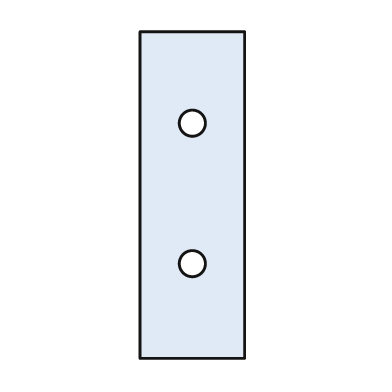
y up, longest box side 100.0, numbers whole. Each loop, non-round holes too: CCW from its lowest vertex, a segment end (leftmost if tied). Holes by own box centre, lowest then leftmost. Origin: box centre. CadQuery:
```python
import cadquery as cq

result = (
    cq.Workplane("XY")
    .moveTo(-16.0, -50.0)
    .lineTo(16.0, -50.0)
    .lineTo(16.0, 50.0)
    .lineTo(-16.0, 50.0)
    .close()
    .moveTo(0.0, -21.0)
    .circle(4.0)
    .moveTo(0.0, 22.0)
    .circle(4.0)
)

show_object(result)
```